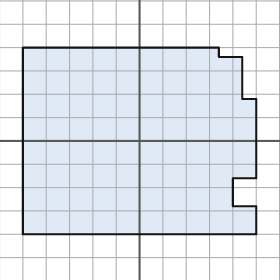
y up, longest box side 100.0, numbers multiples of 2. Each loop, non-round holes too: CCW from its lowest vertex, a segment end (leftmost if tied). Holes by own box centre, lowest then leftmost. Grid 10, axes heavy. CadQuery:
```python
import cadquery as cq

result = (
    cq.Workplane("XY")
    .moveTo(-50.0, -40.0)
    .lineTo(50.0, -40.0)
    .lineTo(50.0, -28.0)
    .lineTo(40.0, -28.0)
    .lineTo(40.0, -16.0)
    .lineTo(50.0, -16.0)
    .lineTo(50.0, 18.0)
    .lineTo(44.0, 18.0)
    .lineTo(44.0, 36.0)
    .lineTo(34.0, 36.0)
    .lineTo(34.0, 40.0)
    .lineTo(-50.0, 40.0)
    .close()
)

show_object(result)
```